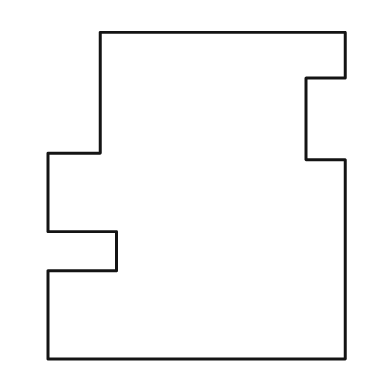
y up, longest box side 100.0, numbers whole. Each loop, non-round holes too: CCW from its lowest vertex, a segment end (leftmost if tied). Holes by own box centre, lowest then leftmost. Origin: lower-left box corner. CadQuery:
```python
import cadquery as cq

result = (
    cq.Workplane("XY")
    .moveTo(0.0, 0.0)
    .lineTo(91.0, 0.0)
    .lineTo(91.0, 61.0)
    .lineTo(79.0, 61.0)
    .lineTo(79.0, 86.0)
    .lineTo(91.0, 86.0)
    .lineTo(91.0, 100.0)
    .lineTo(16.0, 100.0)
    .lineTo(16.0, 63.0)
    .lineTo(0.0, 63.0)
    .lineTo(0.0, 39.0)
    .lineTo(21.0, 39.0)
    .lineTo(21.0, 27.0)
    .lineTo(0.0, 27.0)
    .close()
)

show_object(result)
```